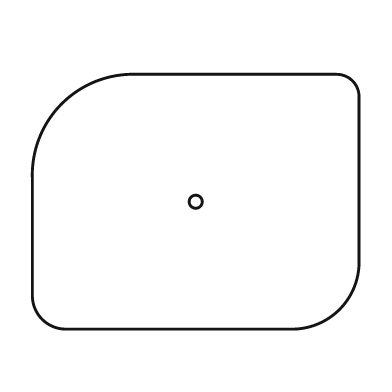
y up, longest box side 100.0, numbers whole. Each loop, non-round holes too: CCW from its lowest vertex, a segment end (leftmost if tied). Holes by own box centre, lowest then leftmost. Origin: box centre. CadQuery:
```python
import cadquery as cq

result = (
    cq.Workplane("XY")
    .moveTo(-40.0, -39.0)
    .lineTo(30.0, -39.0)
    .threePointArc((44.0, -33.0), (50.0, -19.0))
    .lineTo(50.0, 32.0)
    .threePointArc((48.0, 37.0), (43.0, 39.0))
    .lineTo(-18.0, 39.0)
    .threePointArc((-41.0, 30.0), (-50.0, 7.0))
    .lineTo(-50.0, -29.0)
    .threePointArc((-47.0, -36.0), (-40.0, -39.0))
    .close()
    .moveTo(0.0, 0.0)
    .circle(2.0)
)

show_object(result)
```